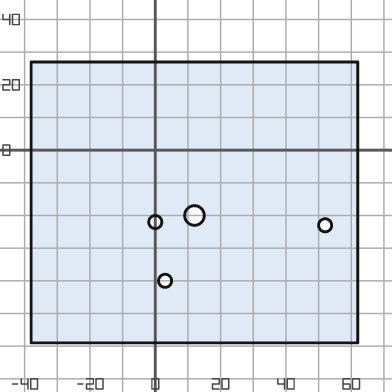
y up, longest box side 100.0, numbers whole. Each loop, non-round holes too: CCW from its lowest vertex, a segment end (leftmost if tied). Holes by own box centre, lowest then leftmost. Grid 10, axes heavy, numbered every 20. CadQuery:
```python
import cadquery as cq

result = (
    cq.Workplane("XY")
    .moveTo(-38.0, -59.0)
    .lineTo(62.0, -59.0)
    .lineTo(62.0, 27.0)
    .lineTo(-38.0, 27.0)
    .close()
    .moveTo(3.0, -40.0)
    .circle(2.0)
    .moveTo(52.0, -23.0)
    .circle(2.0)
    .moveTo(0.0, -22.0)
    .circle(2.0)
    .moveTo(12.0, -20.0)
    .circle(3.0)
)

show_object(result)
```